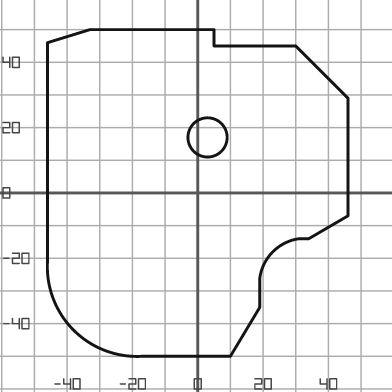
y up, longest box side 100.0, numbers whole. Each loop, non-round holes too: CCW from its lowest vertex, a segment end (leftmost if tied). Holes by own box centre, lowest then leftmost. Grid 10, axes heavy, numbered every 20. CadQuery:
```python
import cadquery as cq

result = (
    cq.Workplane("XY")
    .moveTo(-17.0, -50.0)
    .lineTo(10.0, -50.0)
    .lineTo(19.0, -35.0)
    .lineTo(19.0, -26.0)
    .threePointArc((23.0, -18.0), (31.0, -14.0))
    .lineTo(34.0, -14.0)
    .lineTo(46.0, -7.0)
    .lineTo(46.0, 29.0)
    .lineTo(30.0, 45.0)
    .lineTo(5.0, 45.0)
    .lineTo(5.0, 50.0)
    .lineTo(-33.0, 50.0)
    .lineTo(-46.0, 46.0)
    .lineTo(-46.0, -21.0)
    .threePointArc((-38.0, -42.0), (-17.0, -50.0))
    .close()
    .moveTo(3.0, 17.0)
    .circle(6.0)
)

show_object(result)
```